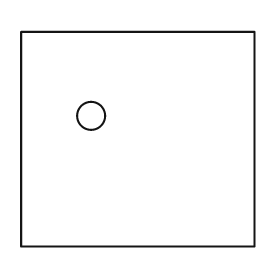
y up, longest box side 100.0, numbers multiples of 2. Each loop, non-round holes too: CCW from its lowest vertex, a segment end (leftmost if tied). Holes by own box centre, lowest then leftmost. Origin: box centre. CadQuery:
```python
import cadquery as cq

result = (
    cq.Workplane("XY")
    .moveTo(-50.0, -46.0)
    .lineTo(50.0, -46.0)
    .lineTo(50.0, 46.0)
    .lineTo(-50.0, 46.0)
    .close()
    .moveTo(-20.0, 10.0)
    .circle(6.0)
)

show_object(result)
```